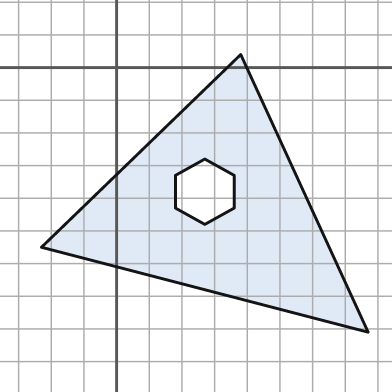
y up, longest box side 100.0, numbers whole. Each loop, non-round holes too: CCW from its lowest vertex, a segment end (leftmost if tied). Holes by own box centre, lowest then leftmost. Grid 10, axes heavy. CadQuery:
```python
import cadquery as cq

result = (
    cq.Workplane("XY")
    .moveTo(77.0, -81.0)
    .lineTo(38.0, 4.0)
    .lineTo(-23.0, -55.0)
    .close()
    .moveTo(27.0, -48.0)
    .lineTo(36.0, -43.0)
    .lineTo(36.0, -33.0)
    .lineTo(27.0, -28.0)
    .lineTo(18.0, -33.0)
    .lineTo(18.0, -43.0)
    .close()
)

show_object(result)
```